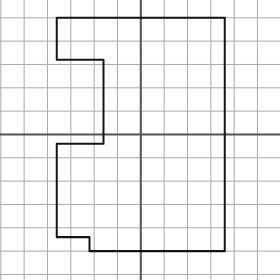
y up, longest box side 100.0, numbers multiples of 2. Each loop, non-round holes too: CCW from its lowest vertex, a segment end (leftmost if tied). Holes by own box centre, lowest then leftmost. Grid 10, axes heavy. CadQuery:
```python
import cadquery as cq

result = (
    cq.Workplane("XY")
    .moveTo(-22.0, -50.0)
    .lineTo(36.0, -50.0)
    .lineTo(36.0, 50.0)
    .lineTo(-36.0, 50.0)
    .lineTo(-36.0, 32.0)
    .lineTo(-16.0, 32.0)
    .lineTo(-16.0, -4.0)
    .lineTo(-36.0, -4.0)
    .lineTo(-36.0, -44.0)
    .lineTo(-22.0, -44.0)
    .close()
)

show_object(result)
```